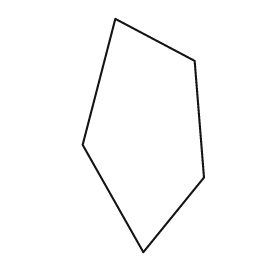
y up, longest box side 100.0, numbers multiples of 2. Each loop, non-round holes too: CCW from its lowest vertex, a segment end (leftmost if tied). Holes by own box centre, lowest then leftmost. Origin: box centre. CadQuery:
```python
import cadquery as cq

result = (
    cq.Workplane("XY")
    .moveTo(0.0, -50.0)
    .lineTo(26.0, -18.0)
    .lineTo(22.0, 32.0)
    .lineTo(-12.0, 50.0)
    .lineTo(-26.0, -4.0)
    .close()
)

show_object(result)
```